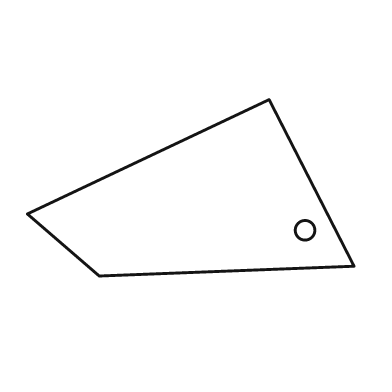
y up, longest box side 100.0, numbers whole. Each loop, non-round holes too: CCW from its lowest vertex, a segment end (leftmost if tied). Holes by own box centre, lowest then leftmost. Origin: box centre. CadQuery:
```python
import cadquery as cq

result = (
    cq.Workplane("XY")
    .moveTo(-28.0, -27.0)
    .lineTo(50.0, -24.0)
    .lineTo(24.0, 27.0)
    .lineTo(-50.0, -8.0)
    .close()
    .moveTo(35.0, -13.0)
    .circle(3.0)
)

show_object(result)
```